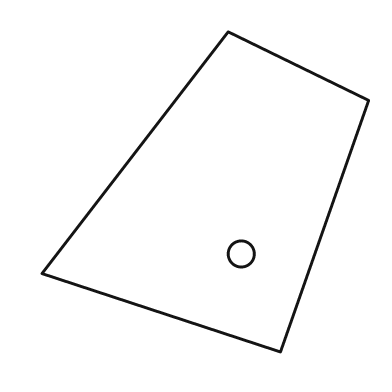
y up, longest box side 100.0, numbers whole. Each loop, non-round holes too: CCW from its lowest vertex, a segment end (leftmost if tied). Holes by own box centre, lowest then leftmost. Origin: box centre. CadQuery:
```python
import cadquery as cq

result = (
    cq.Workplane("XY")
    .moveTo(23.0, -49.0)
    .lineTo(50.0, 28.0)
    .lineTo(7.0, 49.0)
    .lineTo(-50.0, -25.0)
    .close()
    .moveTo(11.0, -19.0)
    .circle(4.0)
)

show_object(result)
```